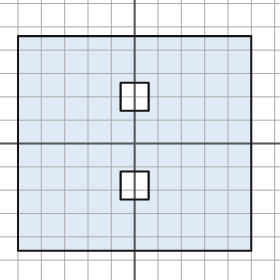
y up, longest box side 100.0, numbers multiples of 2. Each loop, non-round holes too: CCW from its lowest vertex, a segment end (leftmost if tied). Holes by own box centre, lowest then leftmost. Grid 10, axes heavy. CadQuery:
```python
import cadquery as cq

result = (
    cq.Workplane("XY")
    .moveTo(-50.0, -46.0)
    .lineTo(50.0, -46.0)
    .lineTo(50.0, 46.0)
    .lineTo(-50.0, 46.0)
    .close()
    .moveTo(-6.0, -24.0)
    .lineTo(6.0, -24.0)
    .lineTo(6.0, -12.0)
    .lineTo(-6.0, -12.0)
    .close()
    .moveTo(-6.0, 14.0)
    .lineTo(6.0, 14.0)
    .lineTo(6.0, 26.0)
    .lineTo(-6.0, 26.0)
    .close()
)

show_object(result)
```